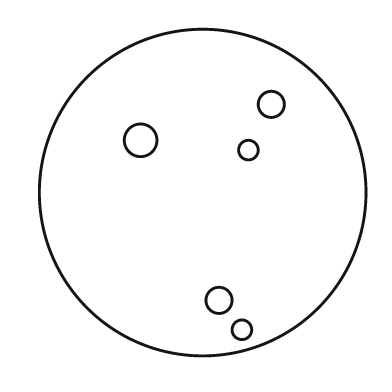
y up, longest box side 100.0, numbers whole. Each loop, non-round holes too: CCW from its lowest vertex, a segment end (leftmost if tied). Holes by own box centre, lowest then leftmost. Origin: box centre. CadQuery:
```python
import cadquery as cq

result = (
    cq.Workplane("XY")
    .moveTo(0.0, 0.0)
    .circle(50.0)
    .moveTo(12.0, -42.0)
    .circle(3.0)
    .moveTo(5.0, -33.0)
    .circle(4.0)
    .moveTo(14.0, 13.0)
    .circle(3.0)
    .moveTo(-19.0, 16.0)
    .circle(5.0)
    .moveTo(21.0, 27.0)
    .circle(4.0)
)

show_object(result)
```